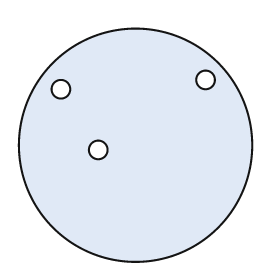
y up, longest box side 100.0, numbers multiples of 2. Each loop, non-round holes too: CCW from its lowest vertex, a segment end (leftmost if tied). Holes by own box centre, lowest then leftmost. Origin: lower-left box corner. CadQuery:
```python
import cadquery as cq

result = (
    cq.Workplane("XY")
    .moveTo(50.0, 50.0)
    .circle(50.0)
    .moveTo(34.0, 48.0)
    .circle(4.0)
    .moveTo(18.0, 74.0)
    .circle(4.0)
    .moveTo(80.0, 78.0)
    .circle(4.0)
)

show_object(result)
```